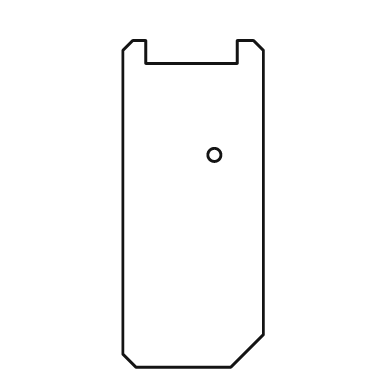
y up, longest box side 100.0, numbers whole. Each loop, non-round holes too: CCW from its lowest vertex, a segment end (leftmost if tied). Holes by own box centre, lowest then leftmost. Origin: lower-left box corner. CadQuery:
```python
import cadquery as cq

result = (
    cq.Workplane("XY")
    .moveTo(4.0, 0.0)
    .lineTo(33.0, 0.0)
    .lineTo(43.0, 10.0)
    .lineTo(43.0, 97.0)
    .lineTo(40.0, 100.0)
    .lineTo(35.0, 100.0)
    .lineTo(35.0, 93.0)
    .lineTo(7.0, 93.0)
    .lineTo(7.0, 100.0)
    .lineTo(3.0, 100.0)
    .lineTo(0.0, 97.0)
    .lineTo(0.0, 4.0)
    .close()
    .moveTo(28.0, 65.0)
    .circle(2.0)
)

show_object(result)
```